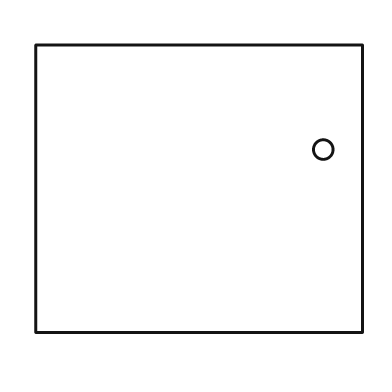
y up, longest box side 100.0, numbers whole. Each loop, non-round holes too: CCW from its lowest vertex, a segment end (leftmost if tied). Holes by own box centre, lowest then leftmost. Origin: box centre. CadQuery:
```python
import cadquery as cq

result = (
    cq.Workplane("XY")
    .moveTo(-50.0, -44.0)
    .lineTo(50.0, -44.0)
    .lineTo(50.0, 44.0)
    .lineTo(-50.0, 44.0)
    .close()
    .moveTo(38.0, 12.0)
    .circle(3.0)
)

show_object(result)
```